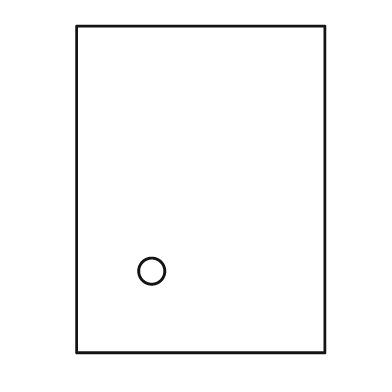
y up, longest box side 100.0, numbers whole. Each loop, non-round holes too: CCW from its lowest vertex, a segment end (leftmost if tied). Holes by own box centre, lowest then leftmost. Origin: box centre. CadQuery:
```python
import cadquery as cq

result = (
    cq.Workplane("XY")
    .moveTo(-38.0, -50.0)
    .lineTo(38.0, -50.0)
    .lineTo(38.0, 50.0)
    .lineTo(-38.0, 50.0)
    .close()
    .moveTo(-15.0, -25.0)
    .circle(4.0)
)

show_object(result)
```